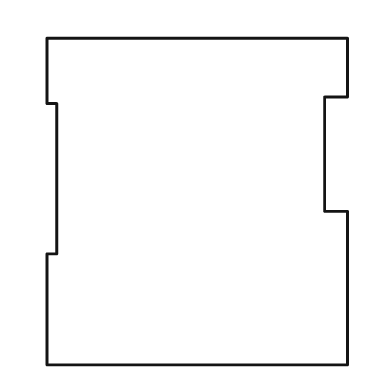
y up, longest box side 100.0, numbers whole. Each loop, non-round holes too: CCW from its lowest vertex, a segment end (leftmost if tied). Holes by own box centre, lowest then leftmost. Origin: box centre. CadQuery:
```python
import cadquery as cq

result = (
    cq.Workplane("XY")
    .moveTo(-46.0, -50.0)
    .lineTo(46.0, -50.0)
    .lineTo(46.0, -3.0)
    .lineTo(39.0, -3.0)
    .lineTo(39.0, 32.0)
    .lineTo(46.0, 32.0)
    .lineTo(46.0, 50.0)
    .lineTo(-46.0, 50.0)
    .lineTo(-46.0, 30.0)
    .lineTo(-43.0, 30.0)
    .lineTo(-43.0, -16.0)
    .lineTo(-46.0, -16.0)
    .close()
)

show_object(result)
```